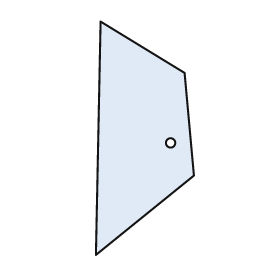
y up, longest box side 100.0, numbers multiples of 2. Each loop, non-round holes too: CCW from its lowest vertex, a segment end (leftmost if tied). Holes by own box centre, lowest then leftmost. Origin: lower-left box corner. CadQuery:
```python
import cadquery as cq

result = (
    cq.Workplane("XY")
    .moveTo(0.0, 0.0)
    .lineTo(42.0, 34.0)
    .lineTo(38.0, 78.0)
    .lineTo(2.0, 100.0)
    .close()
    .moveTo(32.0, 48.0)
    .circle(2.0)
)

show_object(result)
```